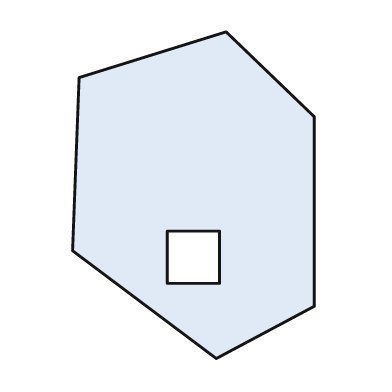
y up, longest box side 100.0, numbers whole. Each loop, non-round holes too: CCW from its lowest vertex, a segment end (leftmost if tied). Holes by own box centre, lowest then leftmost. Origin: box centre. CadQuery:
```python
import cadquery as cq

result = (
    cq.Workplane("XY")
    .moveTo(7.0, -50.0)
    .lineTo(37.0, -34.0)
    .lineTo(37.0, 24.0)
    .lineTo(10.0, 50.0)
    .lineTo(-35.0, 36.0)
    .lineTo(-37.0, -17.0)
    .close()
    .moveTo(-8.0, -27.0)
    .lineTo(8.0, -27.0)
    .lineTo(8.0, -11.0)
    .lineTo(-8.0, -11.0)
    .close()
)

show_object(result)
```